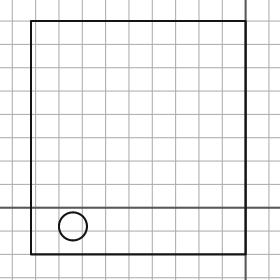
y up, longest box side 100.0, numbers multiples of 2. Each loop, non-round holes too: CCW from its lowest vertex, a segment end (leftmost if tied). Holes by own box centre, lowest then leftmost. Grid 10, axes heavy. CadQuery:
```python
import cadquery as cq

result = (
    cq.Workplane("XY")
    .moveTo(-92.0, -20.0)
    .lineTo(0.0, -20.0)
    .lineTo(0.0, 80.0)
    .lineTo(-92.0, 80.0)
    .close()
    .moveTo(-74.0, -8.0)
    .circle(6.0)
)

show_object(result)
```